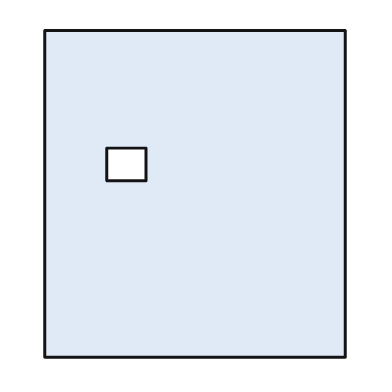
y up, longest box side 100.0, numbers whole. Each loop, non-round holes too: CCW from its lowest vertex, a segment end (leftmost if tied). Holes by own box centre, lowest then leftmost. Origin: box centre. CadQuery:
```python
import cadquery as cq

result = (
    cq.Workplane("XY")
    .moveTo(-46.0, -50.0)
    .lineTo(46.0, -50.0)
    .lineTo(46.0, 50.0)
    .lineTo(-46.0, 50.0)
    .close()
    .moveTo(-27.0, 4.0)
    .lineTo(-15.0, 4.0)
    .lineTo(-15.0, 14.0)
    .lineTo(-27.0, 14.0)
    .close()
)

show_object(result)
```